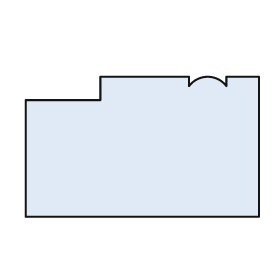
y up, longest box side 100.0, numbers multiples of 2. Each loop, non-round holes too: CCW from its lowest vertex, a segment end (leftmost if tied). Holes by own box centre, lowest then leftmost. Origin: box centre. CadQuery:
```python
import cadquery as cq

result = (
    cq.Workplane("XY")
    .moveTo(-50.0, -30.0)
    .lineTo(50.0, -30.0)
    .lineTo(50.0, 30.0)
    .lineTo(36.0, 30.0)
    .lineTo(36.0, 26.0)
    .threePointArc((28.0, 30.0), (20.0, 26.0))
    .lineTo(20.0, 30.0)
    .lineTo(-18.0, 30.0)
    .lineTo(-18.0, 20.0)
    .lineTo(-50.0, 20.0)
    .close()
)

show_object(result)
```